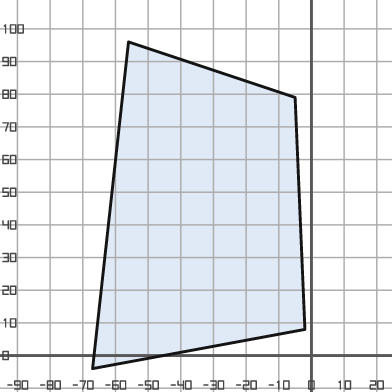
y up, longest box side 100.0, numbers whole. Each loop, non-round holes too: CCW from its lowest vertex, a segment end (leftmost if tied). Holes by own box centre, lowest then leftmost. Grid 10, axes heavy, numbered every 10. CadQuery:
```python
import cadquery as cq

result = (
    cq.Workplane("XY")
    .moveTo(-67.0, -4.0)
    .lineTo(-2.0, 8.0)
    .lineTo(-5.0, 79.0)
    .lineTo(-56.0, 96.0)
    .close()
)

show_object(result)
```